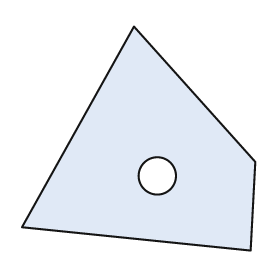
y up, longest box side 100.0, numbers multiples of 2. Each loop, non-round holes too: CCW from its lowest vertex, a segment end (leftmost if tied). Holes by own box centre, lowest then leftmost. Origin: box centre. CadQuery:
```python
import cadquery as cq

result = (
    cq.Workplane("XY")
    .moveTo(48.0, -48.0)
    .lineTo(50.0, -10.0)
    .lineTo(-2.0, 48.0)
    .lineTo(-50.0, -38.0)
    .close()
    .moveTo(8.0, -16.0)
    .circle(8.0)
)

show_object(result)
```